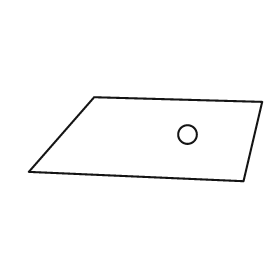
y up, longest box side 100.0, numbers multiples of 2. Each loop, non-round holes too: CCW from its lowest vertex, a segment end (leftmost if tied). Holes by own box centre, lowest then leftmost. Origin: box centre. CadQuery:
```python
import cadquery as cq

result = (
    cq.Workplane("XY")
    .moveTo(42.0, -18.0)
    .lineTo(50.0, 16.0)
    .lineTo(-22.0, 18.0)
    .lineTo(-50.0, -14.0)
    .close()
    .moveTo(18.0, 2.0)
    .circle(4.0)
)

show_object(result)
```